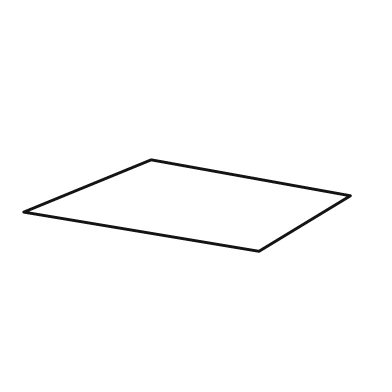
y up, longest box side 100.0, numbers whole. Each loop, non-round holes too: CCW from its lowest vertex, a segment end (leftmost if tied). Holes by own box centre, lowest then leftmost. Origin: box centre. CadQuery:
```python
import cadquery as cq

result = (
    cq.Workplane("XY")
    .moveTo(22.0, -14.0)
    .lineTo(50.0, 3.0)
    .lineTo(-11.0, 14.0)
    .lineTo(-50.0, -2.0)
    .close()
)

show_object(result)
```